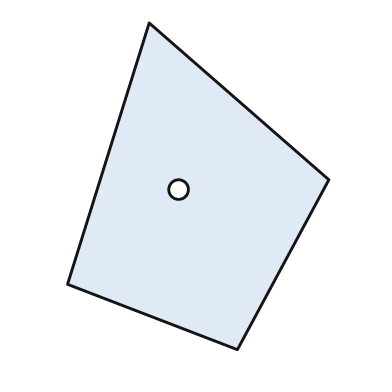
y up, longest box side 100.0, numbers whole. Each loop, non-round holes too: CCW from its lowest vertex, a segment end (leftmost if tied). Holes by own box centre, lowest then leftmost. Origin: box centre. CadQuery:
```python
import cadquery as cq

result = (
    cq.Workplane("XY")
    .moveTo(12.0, -50.0)
    .lineTo(40.0, 2.0)
    .lineTo(-15.0, 50.0)
    .lineTo(-40.0, -30.0)
    .close()
    .moveTo(-6.0, -1.0)
    .circle(3.0)
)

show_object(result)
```